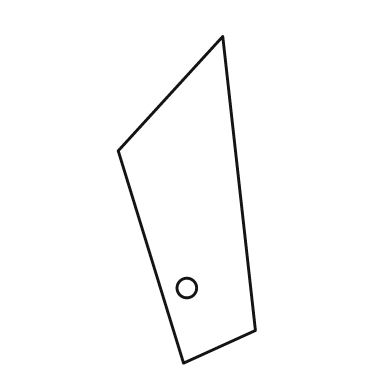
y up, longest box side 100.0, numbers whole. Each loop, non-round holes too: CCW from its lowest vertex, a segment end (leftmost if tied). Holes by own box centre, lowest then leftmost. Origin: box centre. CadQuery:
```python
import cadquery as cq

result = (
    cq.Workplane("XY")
    .moveTo(-1.0, -50.0)
    .lineTo(21.0, -40.0)
    .lineTo(11.0, 50.0)
    .lineTo(-21.0, 15.0)
    .close()
    .moveTo(0.0, -27.0)
    .circle(3.0)
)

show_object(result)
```